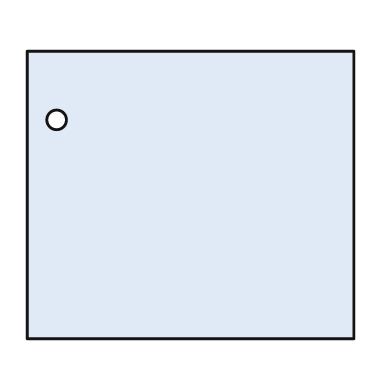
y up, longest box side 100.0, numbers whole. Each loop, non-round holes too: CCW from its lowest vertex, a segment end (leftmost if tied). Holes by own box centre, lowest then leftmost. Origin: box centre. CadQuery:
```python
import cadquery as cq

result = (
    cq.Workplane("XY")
    .moveTo(-50.0, -44.0)
    .lineTo(50.0, -44.0)
    .lineTo(50.0, 44.0)
    .lineTo(-50.0, 44.0)
    .close()
    .moveTo(-41.0, 23.0)
    .circle(3.0)
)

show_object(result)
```